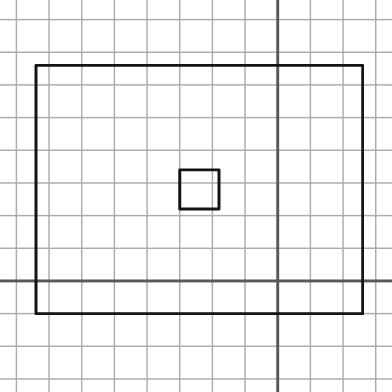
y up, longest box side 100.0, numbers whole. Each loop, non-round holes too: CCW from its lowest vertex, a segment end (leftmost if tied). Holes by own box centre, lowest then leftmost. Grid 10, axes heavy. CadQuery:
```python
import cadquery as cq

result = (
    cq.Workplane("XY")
    .moveTo(-74.0, -10.0)
    .lineTo(26.0, -10.0)
    .lineTo(26.0, 66.0)
    .lineTo(-74.0, 66.0)
    .close()
    .moveTo(-30.0, 22.0)
    .lineTo(-18.0, 22.0)
    .lineTo(-18.0, 34.0)
    .lineTo(-30.0, 34.0)
    .close()
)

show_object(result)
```